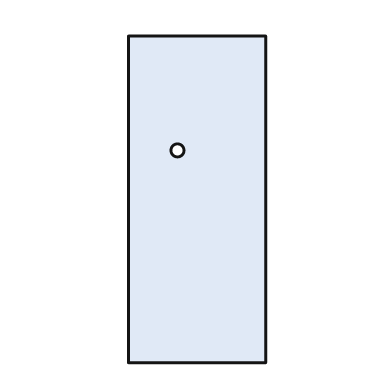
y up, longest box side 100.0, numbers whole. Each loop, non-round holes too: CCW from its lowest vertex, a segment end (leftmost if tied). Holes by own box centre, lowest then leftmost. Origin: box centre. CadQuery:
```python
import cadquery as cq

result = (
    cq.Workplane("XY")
    .moveTo(-21.0, -50.0)
    .lineTo(21.0, -50.0)
    .lineTo(21.0, 50.0)
    .lineTo(-21.0, 50.0)
    .close()
    .moveTo(-6.0, 15.0)
    .circle(2.0)
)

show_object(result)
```